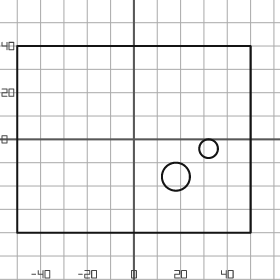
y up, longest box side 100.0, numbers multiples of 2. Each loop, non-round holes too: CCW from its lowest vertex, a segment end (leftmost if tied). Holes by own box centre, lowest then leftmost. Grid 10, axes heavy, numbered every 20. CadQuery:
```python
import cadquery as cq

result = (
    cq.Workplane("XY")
    .moveTo(-50.0, -40.0)
    .lineTo(50.0, -40.0)
    .lineTo(50.0, 40.0)
    .lineTo(-50.0, 40.0)
    .close()
    .moveTo(18.0, -16.0)
    .circle(6.0)
    .moveTo(32.0, -4.0)
    .circle(4.0)
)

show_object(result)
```